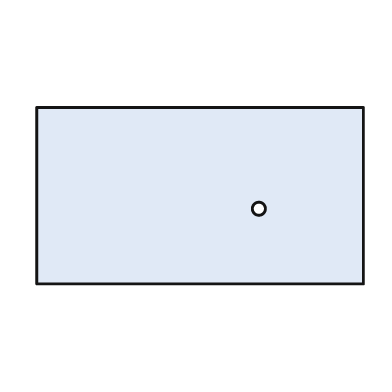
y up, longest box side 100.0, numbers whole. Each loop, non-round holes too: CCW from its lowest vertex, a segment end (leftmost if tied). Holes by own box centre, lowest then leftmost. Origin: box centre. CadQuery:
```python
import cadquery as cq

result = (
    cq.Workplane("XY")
    .moveTo(-50.0, -27.0)
    .lineTo(50.0, -27.0)
    .lineTo(50.0, 27.0)
    .lineTo(-50.0, 27.0)
    .close()
    .moveTo(18.0, -4.0)
    .circle(2.0)
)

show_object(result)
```